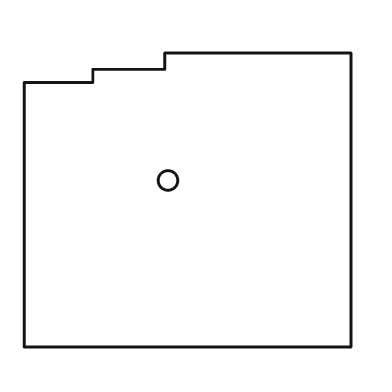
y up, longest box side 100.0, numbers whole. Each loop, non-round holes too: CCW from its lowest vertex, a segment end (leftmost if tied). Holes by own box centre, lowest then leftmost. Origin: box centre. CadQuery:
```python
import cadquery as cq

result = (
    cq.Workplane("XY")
    .moveTo(-50.0, -45.0)
    .lineTo(50.0, -45.0)
    .lineTo(50.0, 45.0)
    .lineTo(-7.0, 45.0)
    .lineTo(-7.0, 40.0)
    .lineTo(-29.0, 40.0)
    .lineTo(-29.0, 36.0)
    .lineTo(-50.0, 36.0)
    .close()
    .moveTo(-6.0, 6.0)
    .circle(3.0)
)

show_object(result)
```